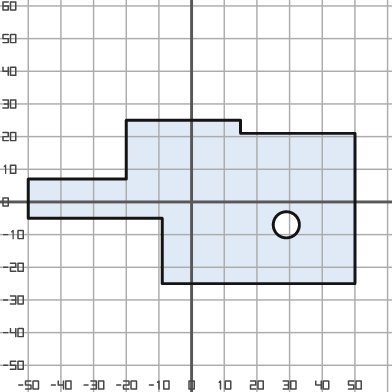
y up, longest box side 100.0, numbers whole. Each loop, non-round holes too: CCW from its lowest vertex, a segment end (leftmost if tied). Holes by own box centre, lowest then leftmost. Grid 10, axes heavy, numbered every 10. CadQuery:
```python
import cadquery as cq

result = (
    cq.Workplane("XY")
    .moveTo(-9.0, -25.0)
    .lineTo(50.0, -25.0)
    .lineTo(50.0, 21.0)
    .lineTo(15.0, 21.0)
    .lineTo(15.0, 25.0)
    .lineTo(-20.0, 25.0)
    .lineTo(-20.0, 7.0)
    .lineTo(-50.0, 7.0)
    .lineTo(-50.0, -5.0)
    .lineTo(-9.0, -5.0)
    .close()
    .moveTo(29.0, -7.0)
    .circle(4.0)
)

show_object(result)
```